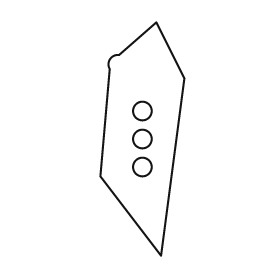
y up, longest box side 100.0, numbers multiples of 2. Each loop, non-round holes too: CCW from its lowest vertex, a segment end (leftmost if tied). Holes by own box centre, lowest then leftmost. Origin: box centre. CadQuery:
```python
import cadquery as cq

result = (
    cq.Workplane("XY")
    .moveTo(8.0, -50.0)
    .lineTo(18.0, 26.0)
    .lineTo(6.0, 50.0)
    .lineTo(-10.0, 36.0)
    .threePointArc((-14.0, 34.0), (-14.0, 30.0))
    .lineTo(-18.0, -16.0)
    .close()
    .moveTo(0.0, -12.0)
    .circle(4.0)
    .moveTo(0.0, 0.0)
    .circle(4.0)
    .moveTo(0.0, 12.0)
    .circle(4.0)
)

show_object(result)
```